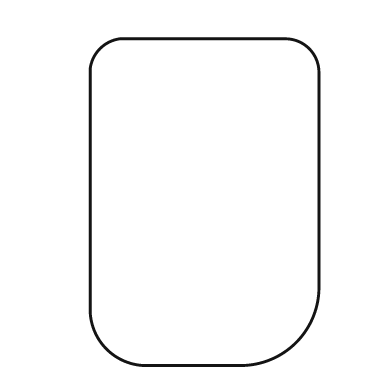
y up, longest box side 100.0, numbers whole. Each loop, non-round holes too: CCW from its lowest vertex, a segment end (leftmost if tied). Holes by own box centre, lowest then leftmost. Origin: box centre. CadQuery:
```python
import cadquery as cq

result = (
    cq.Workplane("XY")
    .moveTo(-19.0, -50.0)
    .lineTo(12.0, -50.0)
    .threePointArc((28.0, -43.0), (35.0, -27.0))
    .lineTo(35.0, 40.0)
    .threePointArc((32.0, 47.0), (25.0, 50.0))
    .lineTo(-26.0, 50.0)
    .threePointArc((-32.0, 47.0), (-35.0, 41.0))
    .lineTo(-35.0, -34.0)
    .threePointArc((-30.0, -45.0), (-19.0, -50.0))
    .close()
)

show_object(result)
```